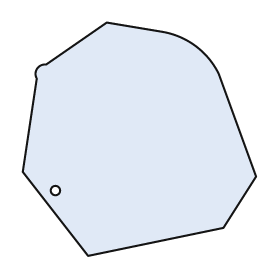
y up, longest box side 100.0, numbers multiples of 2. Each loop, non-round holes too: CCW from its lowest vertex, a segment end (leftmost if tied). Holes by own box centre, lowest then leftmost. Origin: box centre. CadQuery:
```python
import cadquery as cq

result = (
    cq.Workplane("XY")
    .moveTo(-22.0, -50.0)
    .lineTo(36.0, -38.0)
    .lineTo(50.0, -16.0)
    .lineTo(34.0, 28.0)
    .threePointArc((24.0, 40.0), (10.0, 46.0))
    .lineTo(-14.0, 50.0)
    .lineTo(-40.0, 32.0)
    .threePointArc((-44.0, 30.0), (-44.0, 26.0))
    .lineTo(-50.0, -14.0)
    .close()
    .moveTo(-36.0, -22.0)
    .circle(2.0)
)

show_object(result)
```